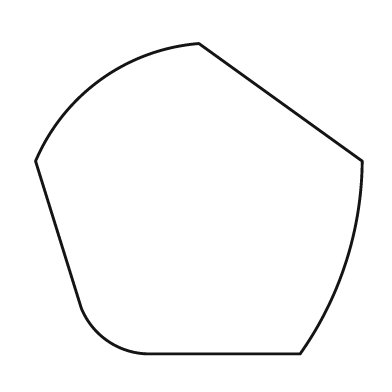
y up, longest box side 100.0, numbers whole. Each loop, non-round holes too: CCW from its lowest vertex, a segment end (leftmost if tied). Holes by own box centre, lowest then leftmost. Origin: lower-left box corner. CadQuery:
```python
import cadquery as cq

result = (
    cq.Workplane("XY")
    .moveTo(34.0, 0.0)
    .lineTo(81.0, 0.0)
    .threePointArc((95.0, 28.0), (100.0, 59.0))
    .lineTo(50.0, 95.0)
    .threePointArc((20.0, 84.0), (0.0, 59.0))
    .lineTo(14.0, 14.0)
    .threePointArc((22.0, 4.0), (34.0, 0.0))
    .close()
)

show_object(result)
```